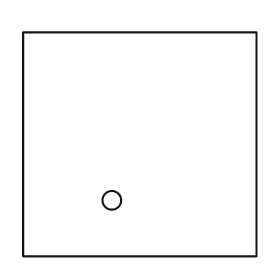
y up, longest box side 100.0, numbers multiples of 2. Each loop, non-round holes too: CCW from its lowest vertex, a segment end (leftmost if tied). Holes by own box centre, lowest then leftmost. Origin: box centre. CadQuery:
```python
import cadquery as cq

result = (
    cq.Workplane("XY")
    .moveTo(-50.0, -48.0)
    .lineTo(50.0, -48.0)
    .lineTo(50.0, 48.0)
    .lineTo(-50.0, 48.0)
    .close()
    .moveTo(-12.0, -24.0)
    .circle(4.0)
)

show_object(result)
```